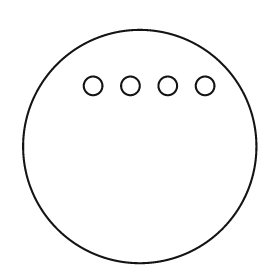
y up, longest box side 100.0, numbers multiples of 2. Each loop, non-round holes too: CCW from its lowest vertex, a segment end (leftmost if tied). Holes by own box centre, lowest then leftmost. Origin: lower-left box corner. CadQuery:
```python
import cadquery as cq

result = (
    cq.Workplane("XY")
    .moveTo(50.0, 50.0)
    .circle(50.0)
    .moveTo(30.0, 76.0)
    .circle(4.0)
    .moveTo(46.0, 76.0)
    .circle(4.0)
    .moveTo(62.0, 76.0)
    .circle(4.0)
    .moveTo(78.0, 76.0)
    .circle(4.0)
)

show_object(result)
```